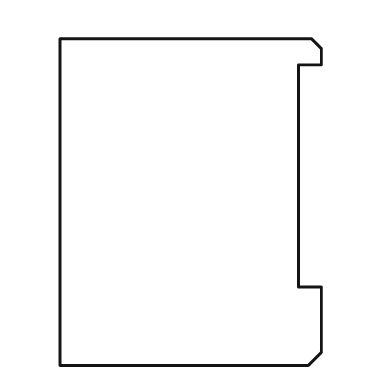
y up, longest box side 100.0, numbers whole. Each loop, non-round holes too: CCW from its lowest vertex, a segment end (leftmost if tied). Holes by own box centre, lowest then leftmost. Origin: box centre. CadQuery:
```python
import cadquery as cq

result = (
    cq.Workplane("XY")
    .moveTo(-40.0, -50.0)
    .lineTo(36.0, -50.0)
    .lineTo(40.0, -46.0)
    .lineTo(40.0, -26.0)
    .lineTo(33.0, -26.0)
    .lineTo(33.0, 42.0)
    .lineTo(40.0, 42.0)
    .lineTo(40.0, 47.0)
    .lineTo(37.0, 50.0)
    .lineTo(-40.0, 50.0)
    .close()
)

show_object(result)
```